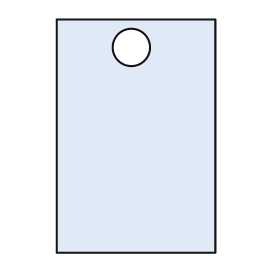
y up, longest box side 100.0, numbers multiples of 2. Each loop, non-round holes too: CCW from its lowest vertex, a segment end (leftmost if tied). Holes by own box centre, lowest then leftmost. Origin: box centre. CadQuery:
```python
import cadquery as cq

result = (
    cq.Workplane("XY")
    .moveTo(-34.0, -50.0)
    .lineTo(34.0, -50.0)
    .lineTo(34.0, 50.0)
    .lineTo(-34.0, 50.0)
    .close()
    .moveTo(-2.0, 38.0)
    .circle(8.0)
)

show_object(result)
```